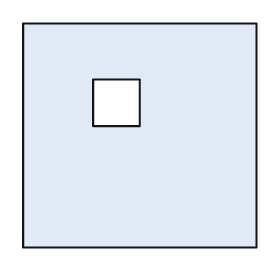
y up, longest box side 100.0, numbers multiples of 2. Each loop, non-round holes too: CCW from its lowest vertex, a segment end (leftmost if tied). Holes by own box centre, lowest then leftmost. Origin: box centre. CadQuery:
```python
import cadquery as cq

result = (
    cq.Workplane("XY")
    .moveTo(-50.0, -48.0)
    .lineTo(50.0, -48.0)
    .lineTo(50.0, 48.0)
    .lineTo(-50.0, 48.0)
    .close()
    .moveTo(-20.0, 4.0)
    .lineTo(0.0, 4.0)
    .lineTo(0.0, 24.0)
    .lineTo(-20.0, 24.0)
    .close()
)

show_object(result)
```